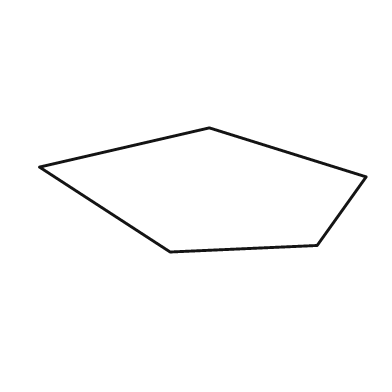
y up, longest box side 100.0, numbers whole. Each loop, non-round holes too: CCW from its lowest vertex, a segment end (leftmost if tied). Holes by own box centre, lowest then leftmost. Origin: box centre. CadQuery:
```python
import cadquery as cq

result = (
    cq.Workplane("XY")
    .moveTo(-10.0, -19.0)
    .lineTo(35.0, -17.0)
    .lineTo(50.0, 4.0)
    .lineTo(2.0, 19.0)
    .lineTo(-50.0, 7.0)
    .close()
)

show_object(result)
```